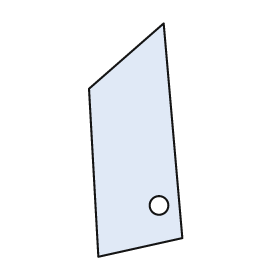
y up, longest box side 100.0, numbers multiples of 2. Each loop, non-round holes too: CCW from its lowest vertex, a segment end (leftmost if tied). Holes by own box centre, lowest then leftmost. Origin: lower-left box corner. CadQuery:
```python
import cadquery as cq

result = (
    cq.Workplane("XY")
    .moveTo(4.0, 0.0)
    .lineTo(40.0, 8.0)
    .lineTo(32.0, 100.0)
    .lineTo(0.0, 72.0)
    .close()
    .moveTo(30.0, 22.0)
    .circle(4.0)
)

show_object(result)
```